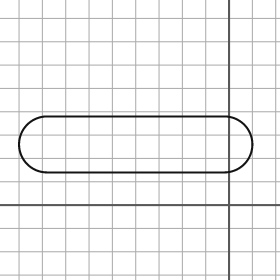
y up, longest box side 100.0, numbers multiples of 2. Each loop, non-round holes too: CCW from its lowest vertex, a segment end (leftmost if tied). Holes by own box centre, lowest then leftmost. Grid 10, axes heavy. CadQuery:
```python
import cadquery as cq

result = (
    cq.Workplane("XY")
    .moveTo(-78.0, 14.0)
    .lineTo(-2.0, 14.0)
    .threePointArc((10.0, 26.0), (-2.0, 38.0))
    .lineTo(-78.0, 38.0)
    .threePointArc((-90.0, 26.0), (-78.0, 14.0))
    .close()
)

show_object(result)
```